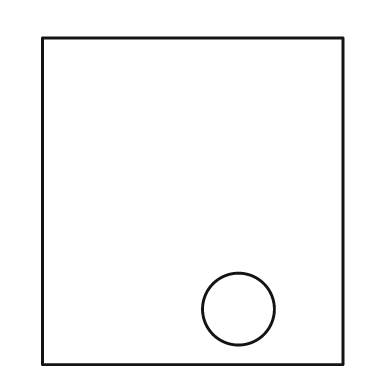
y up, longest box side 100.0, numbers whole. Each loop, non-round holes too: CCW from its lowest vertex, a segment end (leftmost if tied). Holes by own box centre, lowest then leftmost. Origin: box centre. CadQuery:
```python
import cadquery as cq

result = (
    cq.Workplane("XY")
    .moveTo(-46.0, -50.0)
    .lineTo(46.0, -50.0)
    .lineTo(46.0, 50.0)
    .lineTo(-46.0, 50.0)
    .close()
    .moveTo(14.0, -33.0)
    .circle(11.0)
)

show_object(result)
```